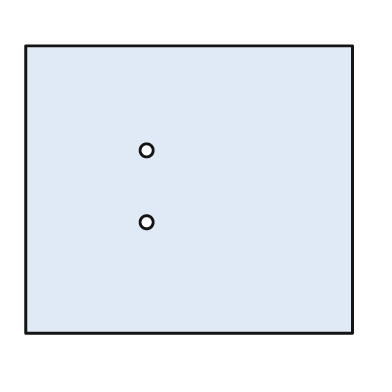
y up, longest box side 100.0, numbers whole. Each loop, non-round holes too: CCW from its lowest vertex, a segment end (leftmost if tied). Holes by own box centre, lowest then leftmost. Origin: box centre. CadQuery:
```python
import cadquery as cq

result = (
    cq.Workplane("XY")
    .moveTo(-50.0, -44.0)
    .lineTo(50.0, -44.0)
    .lineTo(50.0, 44.0)
    .lineTo(-50.0, 44.0)
    .close()
    .moveTo(-13.0, -10.0)
    .circle(2.0)
    .moveTo(-13.0, 12.0)
    .circle(2.0)
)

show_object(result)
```